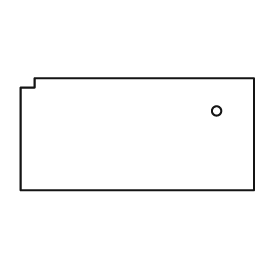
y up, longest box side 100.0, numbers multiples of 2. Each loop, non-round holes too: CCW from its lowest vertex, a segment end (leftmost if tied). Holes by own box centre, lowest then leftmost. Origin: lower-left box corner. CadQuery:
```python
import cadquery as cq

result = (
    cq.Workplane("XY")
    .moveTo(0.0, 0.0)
    .lineTo(100.0, 0.0)
    .lineTo(100.0, 48.0)
    .lineTo(6.0, 48.0)
    .lineTo(6.0, 44.0)
    .lineTo(0.0, 44.0)
    .close()
    .moveTo(84.0, 34.0)
    .circle(2.0)
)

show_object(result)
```